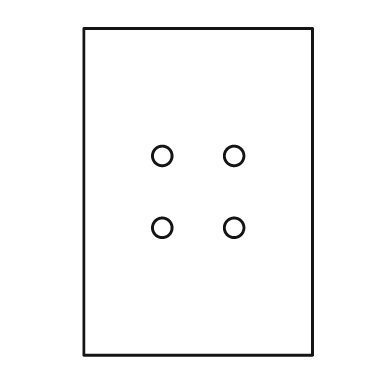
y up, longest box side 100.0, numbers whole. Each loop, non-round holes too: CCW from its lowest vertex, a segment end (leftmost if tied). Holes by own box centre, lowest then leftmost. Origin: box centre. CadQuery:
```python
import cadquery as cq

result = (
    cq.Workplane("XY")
    .moveTo(-35.0, -50.0)
    .lineTo(35.0, -50.0)
    .lineTo(35.0, 50.0)
    .lineTo(-35.0, 50.0)
    .close()
    .moveTo(-11.0, -11.0)
    .circle(3.0)
    .moveTo(11.0, -11.0)
    .circle(3.0)
    .moveTo(-11.0, 11.0)
    .circle(3.0)
    .moveTo(11.0, 11.0)
    .circle(3.0)
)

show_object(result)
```